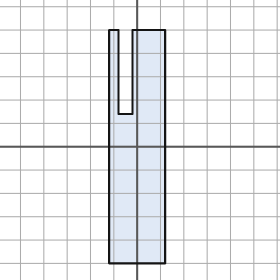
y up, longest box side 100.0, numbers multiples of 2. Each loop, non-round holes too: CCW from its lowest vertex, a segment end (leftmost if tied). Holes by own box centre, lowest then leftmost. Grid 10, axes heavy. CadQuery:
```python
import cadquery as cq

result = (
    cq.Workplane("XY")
    .moveTo(-12.0, -50.0)
    .lineTo(12.0, -50.0)
    .lineTo(12.0, 50.0)
    .lineTo(-2.0, 50.0)
    .lineTo(-2.0, 14.0)
    .lineTo(-8.0, 14.0)
    .lineTo(-8.0, 50.0)
    .lineTo(-12.0, 50.0)
    .close()
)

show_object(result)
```